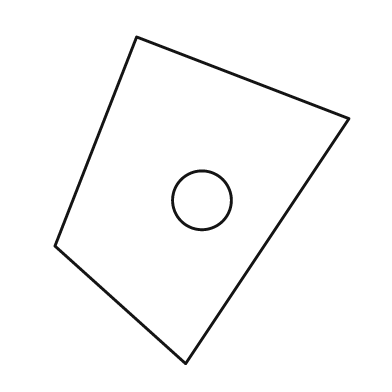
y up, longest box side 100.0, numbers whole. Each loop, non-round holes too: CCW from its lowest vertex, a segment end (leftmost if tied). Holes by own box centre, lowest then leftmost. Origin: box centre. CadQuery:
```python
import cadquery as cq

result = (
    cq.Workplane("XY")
    .moveTo(-5.0, -50.0)
    .lineTo(45.0, 25.0)
    .lineTo(-20.0, 50.0)
    .lineTo(-45.0, -14.0)
    .close()
    .moveTo(0.0, 0.0)
    .circle(9.0)
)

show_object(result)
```